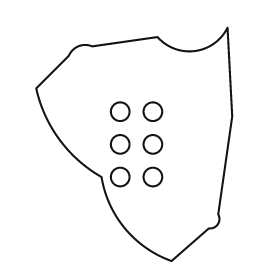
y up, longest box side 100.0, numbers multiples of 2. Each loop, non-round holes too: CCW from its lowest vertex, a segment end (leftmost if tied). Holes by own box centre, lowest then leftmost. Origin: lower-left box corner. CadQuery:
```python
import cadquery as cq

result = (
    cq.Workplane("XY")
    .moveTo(58.0, 0.0)
    .lineTo(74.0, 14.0)
    .threePointArc((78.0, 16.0), (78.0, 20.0))
    .lineTo(84.0, 62.0)
    .lineTo(82.0, 100.0)
    .threePointArc((68.0, 90.0), (52.0, 96.0))
    .lineTo(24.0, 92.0)
    .threePointArc((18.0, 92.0), (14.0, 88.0))
    .lineTo(0.0, 74.0)
    .threePointArc((10.0, 52.0), (28.0, 36.0))
    .threePointArc((38.0, 14.0), (58.0, 0.0))
    .close()
    .moveTo(36.0, 36.0)
    .circle(4.0)
    .moveTo(50.0, 36.0)
    .circle(4.0)
    .moveTo(36.0, 50.0)
    .circle(4.0)
    .moveTo(50.0, 50.0)
    .circle(4.0)
    .moveTo(36.0, 64.0)
    .circle(4.0)
    .moveTo(50.0, 64.0)
    .circle(4.0)
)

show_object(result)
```